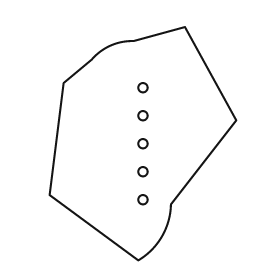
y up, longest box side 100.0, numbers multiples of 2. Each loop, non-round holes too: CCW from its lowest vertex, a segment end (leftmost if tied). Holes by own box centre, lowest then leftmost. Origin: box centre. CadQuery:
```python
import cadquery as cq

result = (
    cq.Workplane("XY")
    .moveTo(-2.0, -50.0)
    .threePointArc((8.0, -40.0), (12.0, -26.0))
    .lineTo(40.0, 10.0)
    .lineTo(18.0, 50.0)
    .lineTo(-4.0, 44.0)
    .threePointArc((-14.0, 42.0), (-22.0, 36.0))
    .lineTo(-34.0, 26.0)
    .lineTo(-40.0, -22.0)
    .close()
    .moveTo(0.0, -24.0)
    .circle(2.0)
    .moveTo(0.0, -12.0)
    .circle(2.0)
    .moveTo(0.0, 0.0)
    .circle(2.0)
    .moveTo(0.0, 12.0)
    .circle(2.0)
    .moveTo(0.0, 24.0)
    .circle(2.0)
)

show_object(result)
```